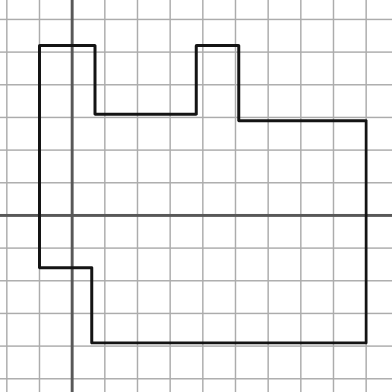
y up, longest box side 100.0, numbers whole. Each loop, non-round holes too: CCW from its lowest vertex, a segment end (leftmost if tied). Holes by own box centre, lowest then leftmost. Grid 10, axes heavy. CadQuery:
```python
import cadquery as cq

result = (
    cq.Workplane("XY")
    .moveTo(6.0, -39.0)
    .lineTo(90.0, -39.0)
    .lineTo(90.0, 29.0)
    .lineTo(51.0, 29.0)
    .lineTo(51.0, 52.0)
    .lineTo(38.0, 52.0)
    .lineTo(38.0, 31.0)
    .lineTo(7.0, 31.0)
    .lineTo(7.0, 52.0)
    .lineTo(-10.0, 52.0)
    .lineTo(-10.0, -16.0)
    .lineTo(6.0, -16.0)
    .close()
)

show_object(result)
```